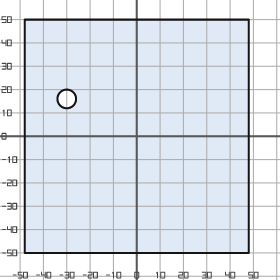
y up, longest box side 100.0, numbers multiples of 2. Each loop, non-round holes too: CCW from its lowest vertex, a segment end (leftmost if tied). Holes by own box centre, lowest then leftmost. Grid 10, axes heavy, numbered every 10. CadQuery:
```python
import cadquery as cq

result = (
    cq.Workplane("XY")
    .moveTo(-48.0, -50.0)
    .lineTo(48.0, -50.0)
    .lineTo(48.0, 50.0)
    .lineTo(-48.0, 50.0)
    .close()
    .moveTo(-30.0, 16.0)
    .circle(4.0)
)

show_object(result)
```